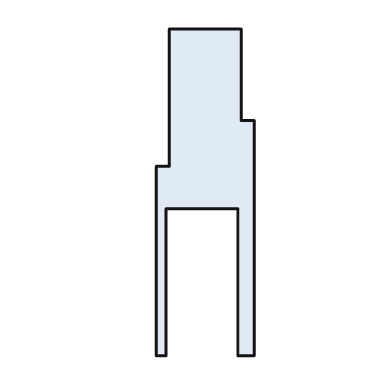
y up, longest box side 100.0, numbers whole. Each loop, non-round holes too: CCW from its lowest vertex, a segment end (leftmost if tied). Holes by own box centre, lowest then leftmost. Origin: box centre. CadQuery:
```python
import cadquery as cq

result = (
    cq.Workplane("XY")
    .moveTo(-15.0, -50.0)
    .lineTo(-12.0, -50.0)
    .lineTo(-12.0, -5.0)
    .lineTo(10.0, -5.0)
    .lineTo(10.0, -50.0)
    .lineTo(15.0, -50.0)
    .lineTo(15.0, 22.0)
    .lineTo(11.0, 22.0)
    .lineTo(11.0, 50.0)
    .lineTo(-11.0, 50.0)
    .lineTo(-11.0, 8.0)
    .lineTo(-15.0, 8.0)
    .close()
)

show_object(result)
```